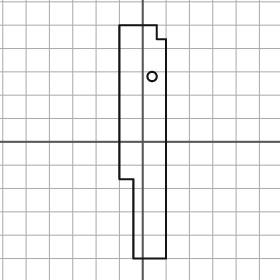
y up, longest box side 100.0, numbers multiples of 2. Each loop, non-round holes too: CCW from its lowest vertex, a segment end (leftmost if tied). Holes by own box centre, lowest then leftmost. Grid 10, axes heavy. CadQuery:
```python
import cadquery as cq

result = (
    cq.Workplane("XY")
    .moveTo(-4.0, -50.0)
    .lineTo(10.0, -50.0)
    .lineTo(10.0, 44.0)
    .lineTo(6.0, 44.0)
    .lineTo(6.0, 50.0)
    .lineTo(-10.0, 50.0)
    .lineTo(-10.0, -16.0)
    .lineTo(-4.0, -16.0)
    .close()
    .moveTo(4.0, 28.0)
    .circle(2.0)
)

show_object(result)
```